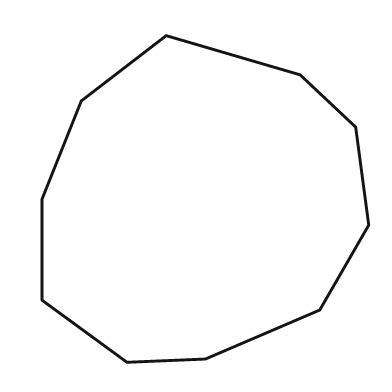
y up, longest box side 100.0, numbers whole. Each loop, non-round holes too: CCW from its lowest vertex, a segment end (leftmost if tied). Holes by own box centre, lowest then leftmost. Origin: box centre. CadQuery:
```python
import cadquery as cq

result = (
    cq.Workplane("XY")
    .moveTo(-24.0, -50.0)
    .lineTo(0.0, -49.0)
    .lineTo(35.0, -34.0)
    .lineTo(50.0, -8.0)
    .lineTo(46.0, 22.0)
    .lineTo(29.0, 38.0)
    .lineTo(-12.0, 50.0)
    .lineTo(-38.0, 30.0)
    .lineTo(-50.0, 0.0)
    .lineTo(-50.0, -31.0)
    .close()
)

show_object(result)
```